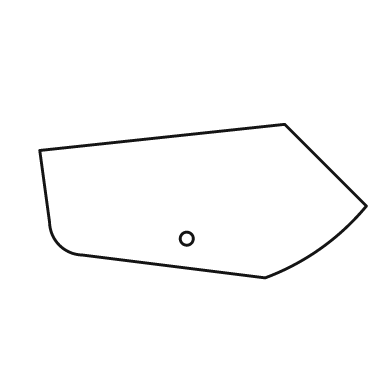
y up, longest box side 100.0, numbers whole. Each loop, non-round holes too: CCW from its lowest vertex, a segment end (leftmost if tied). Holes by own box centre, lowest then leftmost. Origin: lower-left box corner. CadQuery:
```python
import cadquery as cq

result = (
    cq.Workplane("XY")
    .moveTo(69.0, 0.0)
    .threePointArc((86.0, 9.0), (100.0, 22.0))
    .lineTo(75.0, 47.0)
    .lineTo(0.0, 39.0)
    .lineTo(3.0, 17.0)
    .threePointArc((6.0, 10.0), (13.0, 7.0))
    .close()
    .moveTo(45.0, 12.0)
    .circle(2.0)
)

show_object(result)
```